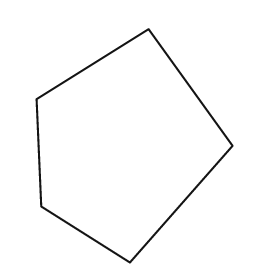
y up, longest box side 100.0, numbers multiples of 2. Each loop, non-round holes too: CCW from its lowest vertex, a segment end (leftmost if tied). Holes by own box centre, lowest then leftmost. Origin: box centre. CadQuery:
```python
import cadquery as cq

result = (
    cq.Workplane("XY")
    .moveTo(-2.0, -50.0)
    .lineTo(42.0, 0.0)
    .lineTo(6.0, 50.0)
    .lineTo(-42.0, 20.0)
    .lineTo(-40.0, -26.0)
    .close()
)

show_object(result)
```